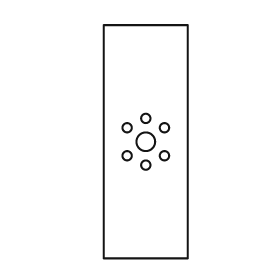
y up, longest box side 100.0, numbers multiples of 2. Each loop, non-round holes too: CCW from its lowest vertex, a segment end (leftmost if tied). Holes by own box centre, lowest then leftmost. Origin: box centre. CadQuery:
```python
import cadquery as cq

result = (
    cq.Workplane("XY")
    .moveTo(-18.0, -50.0)
    .lineTo(18.0, -50.0)
    .lineTo(18.0, 50.0)
    .lineTo(-18.0, 50.0)
    .close()
    .moveTo(0.0, -10.0)
    .circle(2.0)
    .moveTo(-8.0, -6.0)
    .circle(2.0)
    .moveTo(8.0, -6.0)
    .circle(2.0)
    .moveTo(0.0, 0.0)
    .circle(4.0)
    .moveTo(-8.0, 6.0)
    .circle(2.0)
    .moveTo(8.0, 6.0)
    .circle(2.0)
    .moveTo(0.0, 10.0)
    .circle(2.0)
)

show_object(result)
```